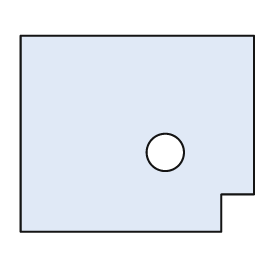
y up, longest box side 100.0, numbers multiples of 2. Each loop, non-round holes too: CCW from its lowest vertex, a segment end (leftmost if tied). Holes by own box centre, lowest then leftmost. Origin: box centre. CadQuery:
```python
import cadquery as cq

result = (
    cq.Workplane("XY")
    .moveTo(-50.0, -42.0)
    .lineTo(36.0, -42.0)
    .lineTo(36.0, -26.0)
    .lineTo(50.0, -26.0)
    .lineTo(50.0, 42.0)
    .lineTo(-50.0, 42.0)
    .close()
    .moveTo(12.0, -8.0)
    .circle(8.0)
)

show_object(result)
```